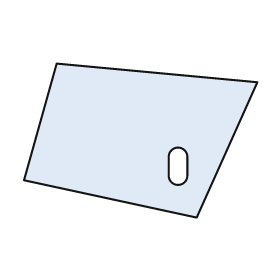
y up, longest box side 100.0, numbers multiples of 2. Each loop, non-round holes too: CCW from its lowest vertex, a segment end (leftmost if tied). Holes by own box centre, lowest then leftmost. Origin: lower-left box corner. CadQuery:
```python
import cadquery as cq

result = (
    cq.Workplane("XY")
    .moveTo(74.0, 0.0)
    .lineTo(100.0, 58.0)
    .lineTo(14.0, 66.0)
    .lineTo(0.0, 16.0)
    .close()
    .moveTo(62.0, 18.0)
    .threePointArc((66.0, 14.0), (70.0, 18.0))
    .lineTo(70.0, 26.0)
    .threePointArc((66.0, 30.0), (62.0, 26.0))
    .close()
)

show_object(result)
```